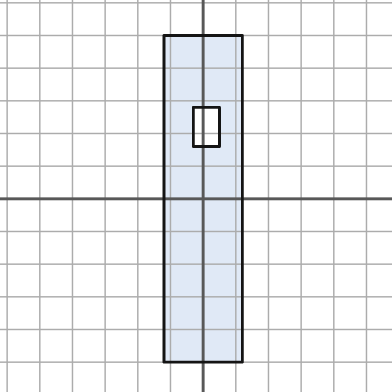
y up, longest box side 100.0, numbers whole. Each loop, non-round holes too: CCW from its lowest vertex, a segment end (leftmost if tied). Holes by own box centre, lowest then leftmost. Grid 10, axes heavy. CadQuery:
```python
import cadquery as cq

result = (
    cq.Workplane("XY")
    .moveTo(-12.0, -50.0)
    .lineTo(12.0, -50.0)
    .lineTo(12.0, 50.0)
    .lineTo(-12.0, 50.0)
    .close()
    .moveTo(-3.0, 16.0)
    .lineTo(5.0, 16.0)
    .lineTo(5.0, 28.0)
    .lineTo(-3.0, 28.0)
    .close()
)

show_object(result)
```